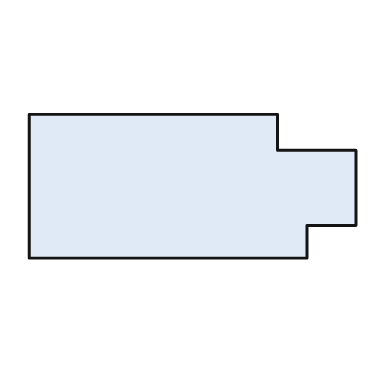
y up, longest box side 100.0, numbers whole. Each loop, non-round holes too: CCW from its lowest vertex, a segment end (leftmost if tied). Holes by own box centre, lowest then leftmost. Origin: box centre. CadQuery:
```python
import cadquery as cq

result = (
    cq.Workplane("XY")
    .moveTo(-50.0, -22.0)
    .lineTo(35.0, -22.0)
    .lineTo(35.0, -12.0)
    .lineTo(50.0, -12.0)
    .lineTo(50.0, 11.0)
    .lineTo(26.0, 11.0)
    .lineTo(26.0, 22.0)
    .lineTo(-50.0, 22.0)
    .close()
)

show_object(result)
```